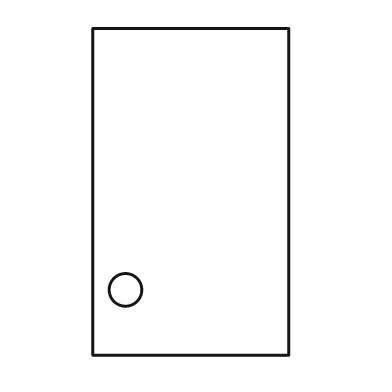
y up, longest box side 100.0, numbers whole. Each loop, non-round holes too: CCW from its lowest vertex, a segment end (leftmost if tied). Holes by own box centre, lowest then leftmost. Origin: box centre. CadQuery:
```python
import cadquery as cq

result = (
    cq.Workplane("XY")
    .moveTo(-30.0, -50.0)
    .lineTo(30.0, -50.0)
    .lineTo(30.0, 50.0)
    .lineTo(-30.0, 50.0)
    .close()
    .moveTo(-20.0, -30.0)
    .circle(5.0)
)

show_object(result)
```